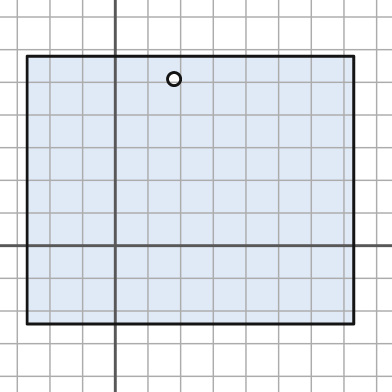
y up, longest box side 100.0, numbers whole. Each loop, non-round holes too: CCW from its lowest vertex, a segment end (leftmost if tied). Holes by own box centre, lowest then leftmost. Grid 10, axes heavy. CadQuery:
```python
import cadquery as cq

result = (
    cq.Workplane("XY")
    .moveTo(-27.0, -24.0)
    .lineTo(73.0, -24.0)
    .lineTo(73.0, 58.0)
    .lineTo(-27.0, 58.0)
    .close()
    .moveTo(18.0, 51.0)
    .circle(2.0)
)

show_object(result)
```